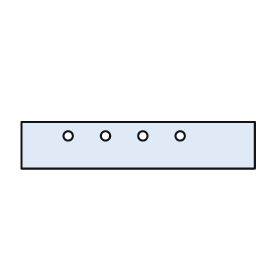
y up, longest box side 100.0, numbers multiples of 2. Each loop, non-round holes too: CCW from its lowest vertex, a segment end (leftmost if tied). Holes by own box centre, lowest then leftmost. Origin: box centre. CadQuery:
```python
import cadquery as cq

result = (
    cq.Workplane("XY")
    .moveTo(-50.0, -10.0)
    .lineTo(50.0, -10.0)
    .lineTo(50.0, 10.0)
    .lineTo(-50.0, 10.0)
    .close()
    .moveTo(-30.0, 4.0)
    .circle(2.0)
    .moveTo(-14.0, 4.0)
    .circle(2.0)
    .moveTo(2.0, 4.0)
    .circle(2.0)
    .moveTo(18.0, 4.0)
    .circle(2.0)
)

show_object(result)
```